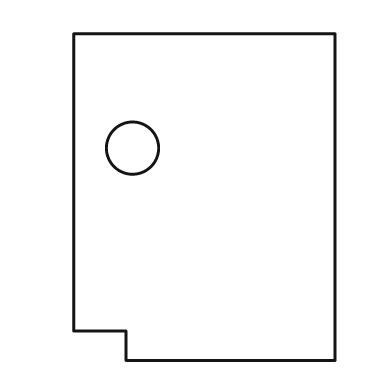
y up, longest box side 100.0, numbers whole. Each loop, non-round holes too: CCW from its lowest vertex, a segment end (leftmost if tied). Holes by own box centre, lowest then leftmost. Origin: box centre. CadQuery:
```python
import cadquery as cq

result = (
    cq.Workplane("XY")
    .moveTo(-24.0, -50.0)
    .lineTo(40.0, -50.0)
    .lineTo(40.0, 50.0)
    .lineTo(-40.0, 50.0)
    .lineTo(-40.0, -41.0)
    .lineTo(-24.0, -41.0)
    .close()
    .moveTo(-22.0, 15.0)
    .circle(8.0)
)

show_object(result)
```